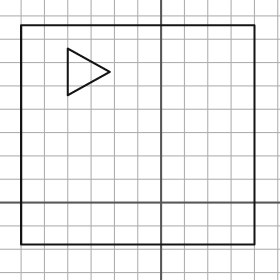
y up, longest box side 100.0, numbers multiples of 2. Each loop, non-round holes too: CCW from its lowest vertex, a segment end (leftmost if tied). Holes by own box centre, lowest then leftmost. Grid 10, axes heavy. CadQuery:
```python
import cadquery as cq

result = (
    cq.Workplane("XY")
    .moveTo(-60.0, -18.0)
    .lineTo(40.0, -18.0)
    .lineTo(40.0, 76.0)
    .lineTo(-60.0, 76.0)
    .close()
    .moveTo(-40.0, 46.0)
    .lineTo(-22.0, 56.0)
    .lineTo(-40.0, 66.0)
    .close()
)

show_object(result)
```